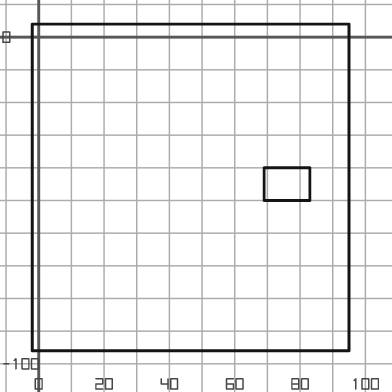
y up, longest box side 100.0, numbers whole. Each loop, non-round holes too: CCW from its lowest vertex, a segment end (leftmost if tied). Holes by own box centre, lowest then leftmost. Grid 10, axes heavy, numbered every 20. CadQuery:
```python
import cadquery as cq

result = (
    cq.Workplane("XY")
    .moveTo(-2.0, -96.0)
    .lineTo(95.0, -96.0)
    .lineTo(95.0, 4.0)
    .lineTo(-2.0, 4.0)
    .close()
    .moveTo(69.0, -50.0)
    .lineTo(83.0, -50.0)
    .lineTo(83.0, -40.0)
    .lineTo(69.0, -40.0)
    .close()
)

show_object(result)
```